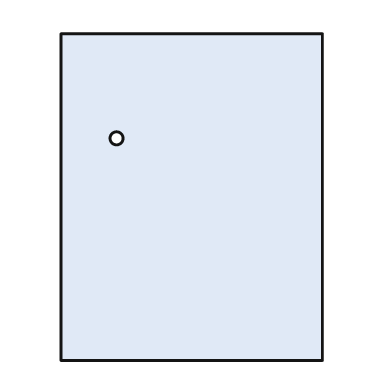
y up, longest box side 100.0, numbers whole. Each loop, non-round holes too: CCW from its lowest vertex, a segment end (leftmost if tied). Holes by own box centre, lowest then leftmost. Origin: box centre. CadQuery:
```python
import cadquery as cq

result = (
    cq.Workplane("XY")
    .moveTo(-40.0, -50.0)
    .lineTo(40.0, -50.0)
    .lineTo(40.0, 50.0)
    .lineTo(-40.0, 50.0)
    .close()
    .moveTo(-23.0, 18.0)
    .circle(2.0)
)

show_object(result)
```